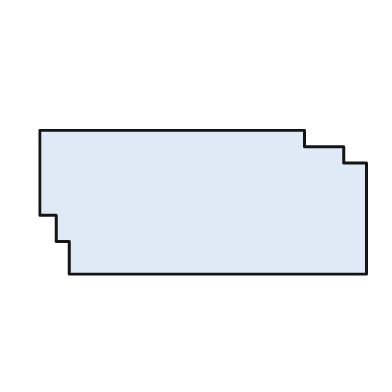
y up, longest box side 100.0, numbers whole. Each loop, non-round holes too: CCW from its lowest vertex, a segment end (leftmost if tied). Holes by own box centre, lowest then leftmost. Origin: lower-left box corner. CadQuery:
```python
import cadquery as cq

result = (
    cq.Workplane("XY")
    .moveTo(9.0, 0.0)
    .lineTo(100.0, 0.0)
    .lineTo(100.0, 34.0)
    .lineTo(93.0, 34.0)
    .lineTo(93.0, 39.0)
    .lineTo(81.0, 39.0)
    .lineTo(81.0, 44.0)
    .lineTo(0.0, 44.0)
    .lineTo(0.0, 18.0)
    .lineTo(5.0, 18.0)
    .lineTo(5.0, 10.0)
    .lineTo(9.0, 10.0)
    .close()
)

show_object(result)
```